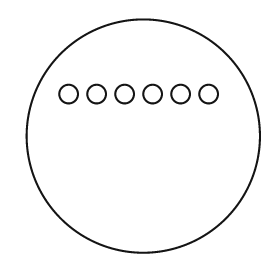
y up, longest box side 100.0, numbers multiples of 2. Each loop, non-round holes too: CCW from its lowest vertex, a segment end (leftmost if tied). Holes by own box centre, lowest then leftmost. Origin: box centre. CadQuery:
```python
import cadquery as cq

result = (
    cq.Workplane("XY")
    .moveTo(0.0, 0.0)
    .circle(50.0)
    .moveTo(-32.0, 18.0)
    .circle(4.0)
    .moveTo(-20.0, 18.0)
    .circle(4.0)
    .moveTo(-8.0, 18.0)
    .circle(4.0)
    .moveTo(4.0, 18.0)
    .circle(4.0)
    .moveTo(16.0, 18.0)
    .circle(4.0)
    .moveTo(28.0, 18.0)
    .circle(4.0)
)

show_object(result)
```